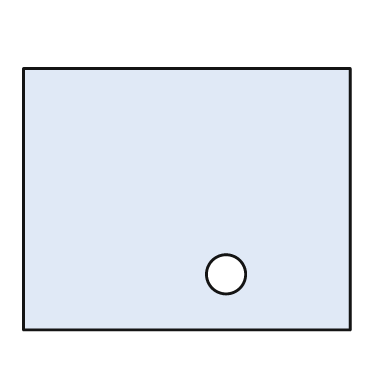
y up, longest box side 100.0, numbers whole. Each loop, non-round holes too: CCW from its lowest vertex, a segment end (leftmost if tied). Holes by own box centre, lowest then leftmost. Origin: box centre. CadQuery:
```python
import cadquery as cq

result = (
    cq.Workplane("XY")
    .moveTo(-50.0, -40.0)
    .lineTo(50.0, -40.0)
    .lineTo(50.0, 40.0)
    .lineTo(-50.0, 40.0)
    .close()
    .moveTo(12.0, -23.0)
    .circle(6.0)
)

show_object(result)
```